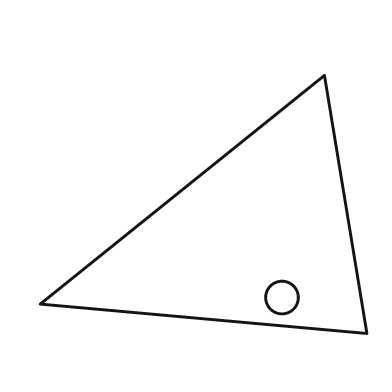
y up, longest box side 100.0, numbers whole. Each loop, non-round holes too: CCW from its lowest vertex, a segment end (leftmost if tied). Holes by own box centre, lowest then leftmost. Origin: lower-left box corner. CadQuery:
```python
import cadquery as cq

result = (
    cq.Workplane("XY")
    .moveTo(100.0, 0.0)
    .lineTo(87.0, 79.0)
    .lineTo(0.0, 9.0)
    .close()
    .moveTo(74.0, 11.0)
    .circle(5.0)
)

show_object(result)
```